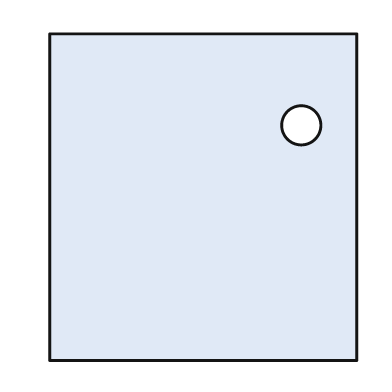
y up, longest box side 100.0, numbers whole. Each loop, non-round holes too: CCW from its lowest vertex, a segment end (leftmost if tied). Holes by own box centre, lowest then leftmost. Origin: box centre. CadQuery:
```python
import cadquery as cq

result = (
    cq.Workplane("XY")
    .moveTo(-47.0, -50.0)
    .lineTo(47.0, -50.0)
    .lineTo(47.0, 50.0)
    .lineTo(-47.0, 50.0)
    .close()
    .moveTo(30.0, 22.0)
    .circle(6.0)
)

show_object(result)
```